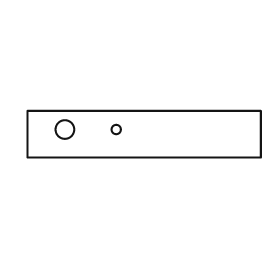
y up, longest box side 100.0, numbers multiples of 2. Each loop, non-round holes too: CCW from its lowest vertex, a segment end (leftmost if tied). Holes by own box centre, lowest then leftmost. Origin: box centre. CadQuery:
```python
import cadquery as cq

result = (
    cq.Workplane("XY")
    .moveTo(-50.0, -10.0)
    .lineTo(50.0, -10.0)
    .lineTo(50.0, 10.0)
    .lineTo(-50.0, 10.0)
    .close()
    .moveTo(-34.0, 2.0)
    .circle(4.0)
    .moveTo(-12.0, 2.0)
    .circle(2.0)
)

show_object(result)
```